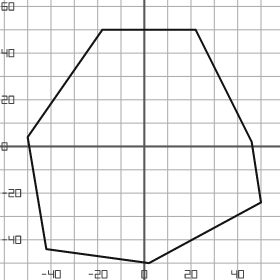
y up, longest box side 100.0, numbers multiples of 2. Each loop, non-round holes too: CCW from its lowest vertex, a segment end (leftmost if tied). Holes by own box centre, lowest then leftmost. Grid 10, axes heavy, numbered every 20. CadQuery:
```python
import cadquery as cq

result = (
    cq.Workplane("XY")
    .moveTo(2.0, -50.0)
    .lineTo(50.0, -24.0)
    .lineTo(46.0, 2.0)
    .lineTo(22.0, 50.0)
    .lineTo(-18.0, 50.0)
    .lineTo(-50.0, 4.0)
    .lineTo(-42.0, -44.0)
    .close()
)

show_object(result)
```